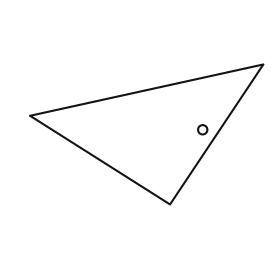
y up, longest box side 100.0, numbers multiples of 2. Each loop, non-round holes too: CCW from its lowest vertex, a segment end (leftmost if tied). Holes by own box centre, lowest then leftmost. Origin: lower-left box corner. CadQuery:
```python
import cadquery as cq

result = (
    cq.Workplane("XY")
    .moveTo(60.0, 0.0)
    .lineTo(100.0, 60.0)
    .lineTo(0.0, 38.0)
    .close()
    .moveTo(74.0, 32.0)
    .circle(2.0)
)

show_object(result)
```